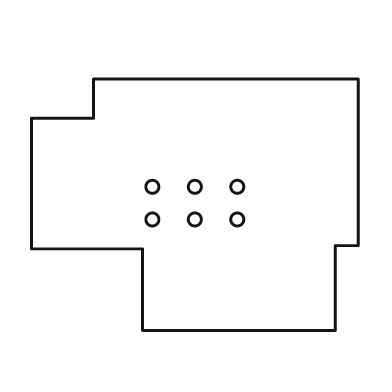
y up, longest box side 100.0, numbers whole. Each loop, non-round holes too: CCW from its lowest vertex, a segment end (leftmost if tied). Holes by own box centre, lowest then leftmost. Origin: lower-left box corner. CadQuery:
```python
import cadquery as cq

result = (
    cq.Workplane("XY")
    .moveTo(34.0, 0.0)
    .lineTo(93.0, 0.0)
    .lineTo(93.0, 26.0)
    .lineTo(100.0, 26.0)
    .lineTo(100.0, 77.0)
    .lineTo(19.0, 77.0)
    .lineTo(19.0, 65.0)
    .lineTo(0.0, 65.0)
    .lineTo(0.0, 25.0)
    .lineTo(34.0, 25.0)
    .close()
    .moveTo(37.0, 34.0)
    .circle(2.0)
    .moveTo(50.0, 34.0)
    .circle(2.0)
    .moveTo(63.0, 34.0)
    .circle(2.0)
    .moveTo(37.0, 44.0)
    .circle(2.0)
    .moveTo(50.0, 44.0)
    .circle(2.0)
    .moveTo(63.0, 44.0)
    .circle(2.0)
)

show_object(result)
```